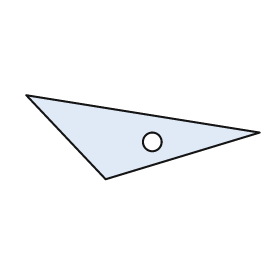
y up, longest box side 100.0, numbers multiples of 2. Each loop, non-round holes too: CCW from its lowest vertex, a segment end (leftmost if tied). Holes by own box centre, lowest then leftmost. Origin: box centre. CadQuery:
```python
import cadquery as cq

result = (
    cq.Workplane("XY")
    .moveTo(-16.0, -18.0)
    .lineTo(50.0, 2.0)
    .lineTo(-50.0, 18.0)
    .close()
    .moveTo(4.0, -2.0)
    .circle(4.0)
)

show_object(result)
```